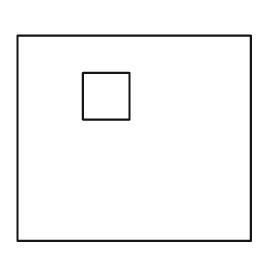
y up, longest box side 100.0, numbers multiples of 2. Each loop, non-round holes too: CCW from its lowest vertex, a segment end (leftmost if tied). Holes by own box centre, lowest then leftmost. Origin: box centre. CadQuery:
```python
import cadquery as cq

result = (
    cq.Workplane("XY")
    .moveTo(-50.0, -44.0)
    .lineTo(50.0, -44.0)
    .lineTo(50.0, 44.0)
    .lineTo(-50.0, 44.0)
    .close()
    .moveTo(-22.0, 8.0)
    .lineTo(-2.0, 8.0)
    .lineTo(-2.0, 28.0)
    .lineTo(-22.0, 28.0)
    .close()
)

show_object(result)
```